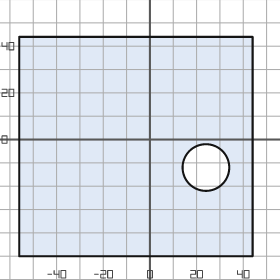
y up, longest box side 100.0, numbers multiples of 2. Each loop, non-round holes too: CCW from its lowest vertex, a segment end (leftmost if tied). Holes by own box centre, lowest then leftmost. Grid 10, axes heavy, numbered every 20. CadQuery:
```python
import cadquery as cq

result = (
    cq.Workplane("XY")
    .moveTo(-56.0, -50.0)
    .lineTo(44.0, -50.0)
    .lineTo(44.0, 44.0)
    .lineTo(-56.0, 44.0)
    .close()
    .moveTo(24.0, -12.0)
    .circle(10.0)
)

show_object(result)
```